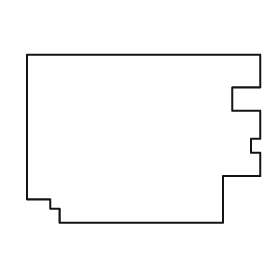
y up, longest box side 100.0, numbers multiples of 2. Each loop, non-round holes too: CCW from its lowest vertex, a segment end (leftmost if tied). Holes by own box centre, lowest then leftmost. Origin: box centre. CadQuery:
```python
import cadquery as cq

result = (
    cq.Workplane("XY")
    .moveTo(-36.0, -36.0)
    .lineTo(34.0, -36.0)
    .lineTo(34.0, -16.0)
    .lineTo(50.0, -16.0)
    .lineTo(50.0, -6.0)
    .lineTo(46.0, -6.0)
    .lineTo(46.0, 0.0)
    .lineTo(50.0, 0.0)
    .lineTo(50.0, 12.0)
    .lineTo(38.0, 12.0)
    .lineTo(38.0, 22.0)
    .lineTo(50.0, 22.0)
    .lineTo(50.0, 36.0)
    .lineTo(-50.0, 36.0)
    .lineTo(-50.0, -26.0)
    .lineTo(-40.0, -26.0)
    .lineTo(-40.0, -30.0)
    .lineTo(-36.0, -30.0)
    .close()
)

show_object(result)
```